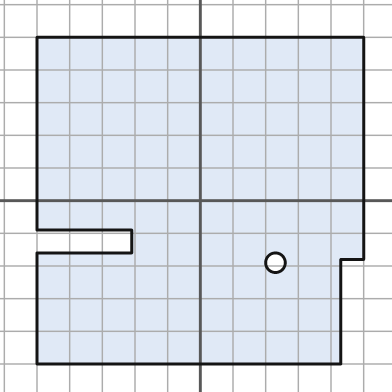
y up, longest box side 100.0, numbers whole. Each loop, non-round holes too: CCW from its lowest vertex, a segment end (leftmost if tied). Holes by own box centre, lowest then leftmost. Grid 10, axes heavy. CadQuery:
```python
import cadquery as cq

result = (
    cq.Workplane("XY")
    .moveTo(-50.0, -50.0)
    .lineTo(43.0, -50.0)
    .lineTo(43.0, -18.0)
    .lineTo(50.0, -18.0)
    .lineTo(50.0, 50.0)
    .lineTo(-50.0, 50.0)
    .lineTo(-50.0, -9.0)
    .lineTo(-21.0, -9.0)
    .lineTo(-21.0, -16.0)
    .lineTo(-50.0, -16.0)
    .close()
    .moveTo(23.0, -19.0)
    .circle(3.0)
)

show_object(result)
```